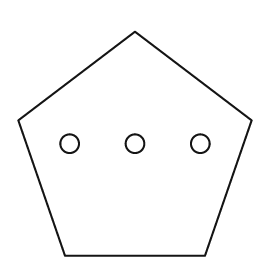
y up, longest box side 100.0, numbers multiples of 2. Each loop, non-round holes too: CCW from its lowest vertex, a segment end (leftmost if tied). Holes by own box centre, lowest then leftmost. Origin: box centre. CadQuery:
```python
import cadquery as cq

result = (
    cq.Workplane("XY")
    .moveTo(-30.0, -48.0)
    .lineTo(30.0, -48.0)
    .lineTo(50.0, 10.0)
    .lineTo(0.0, 48.0)
    .lineTo(-50.0, 10.0)
    .close()
    .moveTo(-28.0, 0.0)
    .circle(4.0)
    .moveTo(0.0, 0.0)
    .circle(4.0)
    .moveTo(28.0, 0.0)
    .circle(4.0)
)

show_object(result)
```